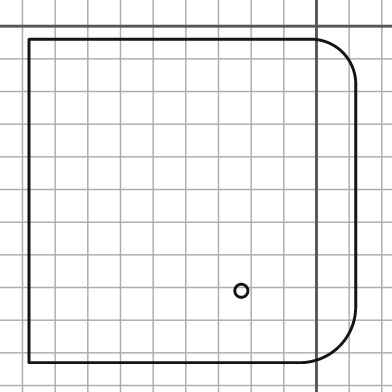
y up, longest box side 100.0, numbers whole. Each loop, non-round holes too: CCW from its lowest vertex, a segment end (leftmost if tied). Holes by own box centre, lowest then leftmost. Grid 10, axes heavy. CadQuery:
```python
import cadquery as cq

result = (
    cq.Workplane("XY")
    .moveTo(-88.0, -103.0)
    .lineTo(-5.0, -103.0)
    .threePointArc((7.0, -98.0), (12.0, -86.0))
    .lineTo(12.0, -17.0)
    .threePointArc((8.0, -8.0), (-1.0, -4.0))
    .lineTo(-88.0, -4.0)
    .close()
    .moveTo(-23.0, -81.0)
    .circle(2.0)
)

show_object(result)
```